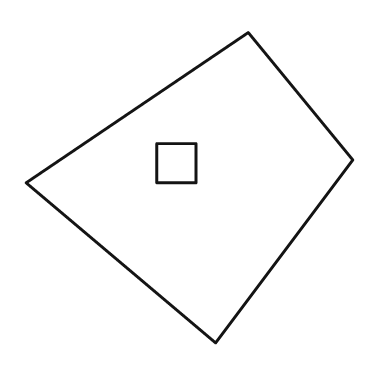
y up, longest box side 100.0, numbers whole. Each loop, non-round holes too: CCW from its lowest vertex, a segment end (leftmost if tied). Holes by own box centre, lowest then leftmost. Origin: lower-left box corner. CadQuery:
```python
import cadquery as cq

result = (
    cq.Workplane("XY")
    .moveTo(58.0, 0.0)
    .lineTo(100.0, 56.0)
    .lineTo(68.0, 95.0)
    .lineTo(0.0, 49.0)
    .close()
    .moveTo(40.0, 49.0)
    .lineTo(52.0, 49.0)
    .lineTo(52.0, 61.0)
    .lineTo(40.0, 61.0)
    .close()
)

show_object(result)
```